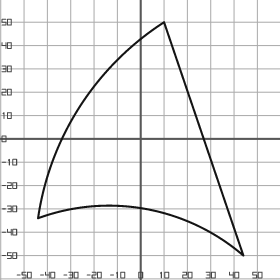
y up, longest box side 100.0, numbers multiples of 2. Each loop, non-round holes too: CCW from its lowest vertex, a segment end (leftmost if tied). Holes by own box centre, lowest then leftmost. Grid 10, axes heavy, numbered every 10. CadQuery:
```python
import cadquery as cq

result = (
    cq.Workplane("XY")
    .moveTo(44.0, -50.0)
    .lineTo(10.0, 50.0)
    .threePointArc((-26.0, 14.0), (-44.0, -34.0))
    .threePointArc((2.0, -30.0), (44.0, -50.0))
    .close()
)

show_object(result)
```